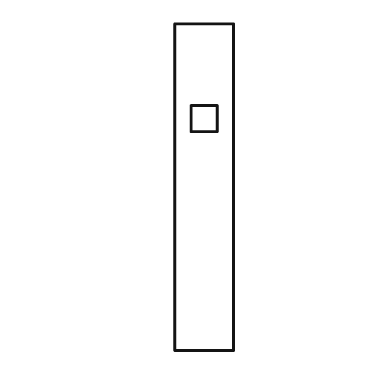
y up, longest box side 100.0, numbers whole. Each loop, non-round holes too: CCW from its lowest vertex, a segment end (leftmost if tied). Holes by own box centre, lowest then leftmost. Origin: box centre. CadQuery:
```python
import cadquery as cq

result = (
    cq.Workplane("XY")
    .moveTo(-9.0, -50.0)
    .lineTo(9.0, -50.0)
    .lineTo(9.0, 50.0)
    .lineTo(-9.0, 50.0)
    .close()
    .moveTo(-4.0, 17.0)
    .lineTo(4.0, 17.0)
    .lineTo(4.0, 25.0)
    .lineTo(-4.0, 25.0)
    .close()
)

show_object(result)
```